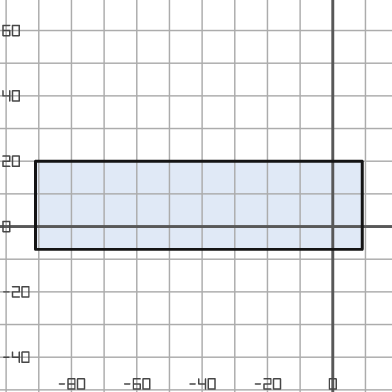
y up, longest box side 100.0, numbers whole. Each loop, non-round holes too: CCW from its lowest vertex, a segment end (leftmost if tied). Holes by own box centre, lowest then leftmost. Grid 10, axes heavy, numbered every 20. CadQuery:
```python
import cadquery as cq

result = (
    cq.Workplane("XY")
    .moveTo(-91.0, -7.0)
    .lineTo(9.0, -7.0)
    .lineTo(9.0, 20.0)
    .lineTo(-91.0, 20.0)
    .close()
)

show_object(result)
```